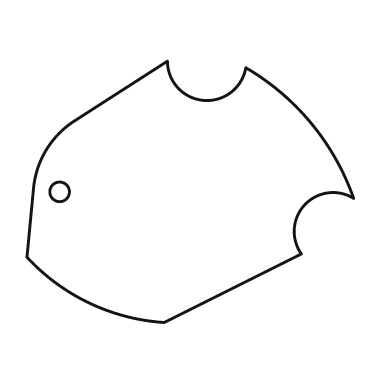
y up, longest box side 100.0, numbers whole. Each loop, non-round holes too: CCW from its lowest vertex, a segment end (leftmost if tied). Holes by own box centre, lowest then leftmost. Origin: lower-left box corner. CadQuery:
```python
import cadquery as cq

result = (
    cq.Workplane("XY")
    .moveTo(42.0, 0.0)
    .lineTo(84.0, 21.0)
    .threePointArc((85.0, 36.0), (100.0, 38.0))
    .threePointArc((87.0, 61.0), (67.0, 78.0))
    .threePointArc((54.0, 68.0), (43.0, 80.0))
    .lineTo(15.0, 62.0)
    .threePointArc((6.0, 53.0), (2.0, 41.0))
    .lineTo(0.0, 20.0)
    .threePointArc((19.0, 6.0), (42.0, 0.0))
    .close()
    .moveTo(10.0, 40.0)
    .circle(3.0)
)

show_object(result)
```